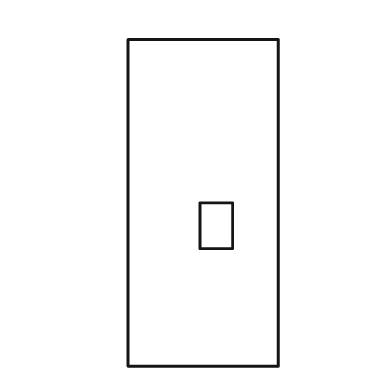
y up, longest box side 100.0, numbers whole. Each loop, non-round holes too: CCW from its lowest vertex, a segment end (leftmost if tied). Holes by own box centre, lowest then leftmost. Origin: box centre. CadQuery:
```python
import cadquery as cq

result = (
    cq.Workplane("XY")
    .moveTo(-23.0, -50.0)
    .lineTo(23.0, -50.0)
    .lineTo(23.0, 50.0)
    .lineTo(-23.0, 50.0)
    .close()
    .moveTo(-1.0, -14.0)
    .lineTo(9.0, -14.0)
    .lineTo(9.0, 0.0)
    .lineTo(-1.0, 0.0)
    .close()
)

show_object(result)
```